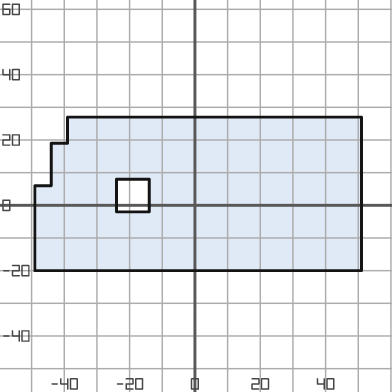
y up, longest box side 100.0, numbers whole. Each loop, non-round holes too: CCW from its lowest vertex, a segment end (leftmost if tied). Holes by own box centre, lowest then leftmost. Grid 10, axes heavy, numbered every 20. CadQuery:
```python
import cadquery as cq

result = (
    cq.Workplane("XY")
    .moveTo(-49.0, -20.0)
    .lineTo(51.0, -20.0)
    .lineTo(51.0, 27.0)
    .lineTo(-39.0, 27.0)
    .lineTo(-39.0, 19.0)
    .lineTo(-44.0, 19.0)
    .lineTo(-44.0, 6.0)
    .lineTo(-49.0, 6.0)
    .close()
    .moveTo(-24.0, -2.0)
    .lineTo(-14.0, -2.0)
    .lineTo(-14.0, 8.0)
    .lineTo(-24.0, 8.0)
    .close()
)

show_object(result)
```